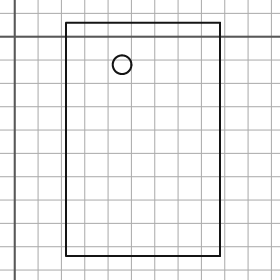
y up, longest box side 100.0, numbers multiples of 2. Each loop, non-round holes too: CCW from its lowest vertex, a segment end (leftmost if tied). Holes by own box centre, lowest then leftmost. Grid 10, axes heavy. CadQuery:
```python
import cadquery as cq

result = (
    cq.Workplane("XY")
    .moveTo(22.0, -94.0)
    .lineTo(88.0, -94.0)
    .lineTo(88.0, 6.0)
    .lineTo(22.0, 6.0)
    .close()
    .moveTo(46.0, -12.0)
    .circle(4.0)
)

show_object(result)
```